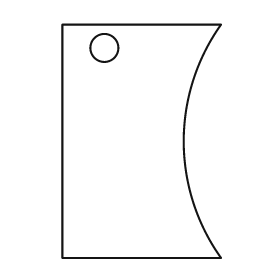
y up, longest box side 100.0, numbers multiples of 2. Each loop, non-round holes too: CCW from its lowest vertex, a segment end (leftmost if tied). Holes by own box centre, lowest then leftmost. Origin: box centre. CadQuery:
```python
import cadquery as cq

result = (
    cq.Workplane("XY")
    .moveTo(-34.0, -50.0)
    .lineTo(34.0, -50.0)
    .threePointArc((18.0, 0.0), (34.0, 50.0))
    .lineTo(-34.0, 50.0)
    .close()
    .moveTo(-16.0, 40.0)
    .circle(6.0)
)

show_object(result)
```